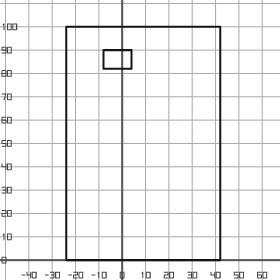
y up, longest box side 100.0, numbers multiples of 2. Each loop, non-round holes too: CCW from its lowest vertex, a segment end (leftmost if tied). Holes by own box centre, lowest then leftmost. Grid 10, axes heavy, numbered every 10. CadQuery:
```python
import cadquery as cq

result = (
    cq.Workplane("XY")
    .moveTo(-24.0, 0.0)
    .lineTo(42.0, 0.0)
    .lineTo(42.0, 100.0)
    .lineTo(-24.0, 100.0)
    .close()
    .moveTo(-8.0, 82.0)
    .lineTo(4.0, 82.0)
    .lineTo(4.0, 90.0)
    .lineTo(-8.0, 90.0)
    .close()
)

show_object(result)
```